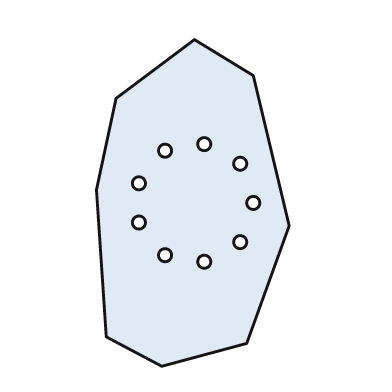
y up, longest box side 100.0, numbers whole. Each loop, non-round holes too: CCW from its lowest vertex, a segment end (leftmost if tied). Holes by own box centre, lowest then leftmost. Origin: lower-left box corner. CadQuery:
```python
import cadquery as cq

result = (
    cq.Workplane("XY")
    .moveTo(20.0, 0.0)
    .lineTo(46.0, 7.0)
    .lineTo(59.0, 43.0)
    .lineTo(48.0, 89.0)
    .lineTo(30.0, 100.0)
    .lineTo(6.0, 82.0)
    .lineTo(0.0, 54.0)
    .lineTo(3.0, 9.0)
    .close()
    .moveTo(33.0, 32.0)
    .circle(2.0)
    .moveTo(21.0, 34.0)
    .circle(2.0)
    .moveTo(44.0, 38.0)
    .circle(2.0)
    .moveTo(13.0, 44.0)
    .circle(2.0)
    .moveTo(48.0, 50.0)
    .circle(2.0)
    .moveTo(13.0, 56.0)
    .circle(2.0)
    .moveTo(44.0, 62.0)
    .circle(2.0)
    .moveTo(21.0, 66.0)
    .circle(2.0)
    .moveTo(33.0, 68.0)
    .circle(2.0)
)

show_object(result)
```